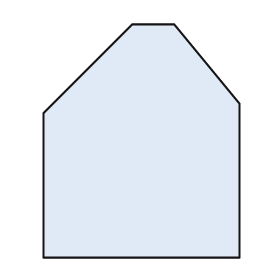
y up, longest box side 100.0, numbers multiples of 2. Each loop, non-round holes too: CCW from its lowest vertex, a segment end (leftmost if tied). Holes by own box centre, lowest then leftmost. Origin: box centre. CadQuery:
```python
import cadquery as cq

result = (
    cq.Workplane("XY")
    .moveTo(-42.0, -50.0)
    .lineTo(42.0, -50.0)
    .lineTo(42.0, 16.0)
    .lineTo(14.0, 50.0)
    .lineTo(-4.0, 50.0)
    .lineTo(-42.0, 12.0)
    .close()
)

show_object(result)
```